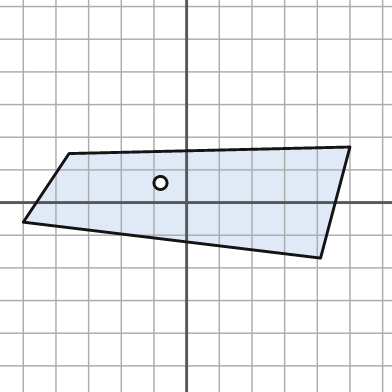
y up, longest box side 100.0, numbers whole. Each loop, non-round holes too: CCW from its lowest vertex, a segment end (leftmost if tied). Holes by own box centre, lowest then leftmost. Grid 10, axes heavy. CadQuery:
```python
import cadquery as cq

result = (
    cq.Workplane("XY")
    .moveTo(41.0, -17.0)
    .lineTo(50.0, 17.0)
    .lineTo(-36.0, 15.0)
    .lineTo(-50.0, -6.0)
    .close()
    .moveTo(-8.0, 6.0)
    .circle(2.0)
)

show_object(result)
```